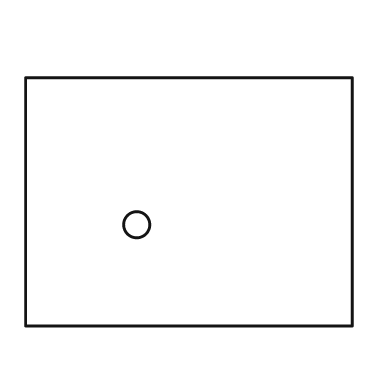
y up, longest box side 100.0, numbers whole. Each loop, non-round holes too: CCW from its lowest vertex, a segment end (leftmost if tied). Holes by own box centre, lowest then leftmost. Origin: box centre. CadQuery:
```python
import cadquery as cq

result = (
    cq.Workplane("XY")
    .moveTo(-50.0, -38.0)
    .lineTo(50.0, -38.0)
    .lineTo(50.0, 38.0)
    .lineTo(-50.0, 38.0)
    .close()
    .moveTo(-16.0, -7.0)
    .circle(4.0)
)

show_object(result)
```